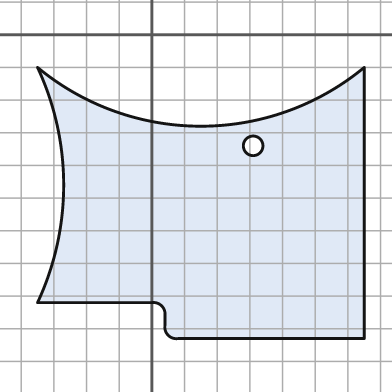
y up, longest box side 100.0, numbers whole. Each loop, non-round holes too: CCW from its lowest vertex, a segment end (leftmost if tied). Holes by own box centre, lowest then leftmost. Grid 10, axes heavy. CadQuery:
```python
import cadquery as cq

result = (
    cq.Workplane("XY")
    .moveTo(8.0, -93.0)
    .lineTo(65.0, -93.0)
    .lineTo(65.0, -10.0)
    .threePointArc((15.0, -28.0), (-35.0, -10.0))
    .threePointArc((-27.0, -46.0), (-35.0, -82.0))
    .lineTo(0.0, -82.0)
    .threePointArc((3.0, -83.0), (4.0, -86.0))
    .lineTo(4.0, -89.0)
    .threePointArc((5.0, -92.0), (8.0, -93.0))
    .close()
    .moveTo(31.0, -34.0)
    .circle(3.0)
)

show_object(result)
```